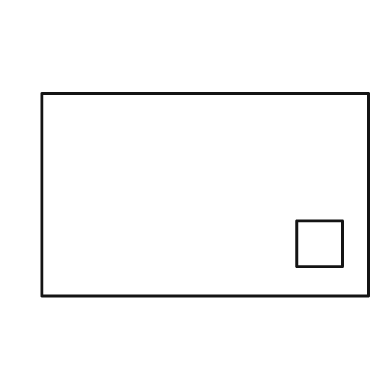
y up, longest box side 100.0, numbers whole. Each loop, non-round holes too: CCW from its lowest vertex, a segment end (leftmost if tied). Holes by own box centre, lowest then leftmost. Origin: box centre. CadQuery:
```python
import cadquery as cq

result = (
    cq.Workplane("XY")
    .moveTo(-50.0, -31.0)
    .lineTo(50.0, -31.0)
    .lineTo(50.0, 31.0)
    .lineTo(-50.0, 31.0)
    .close()
    .moveTo(28.0, -22.0)
    .lineTo(42.0, -22.0)
    .lineTo(42.0, -8.0)
    .lineTo(28.0, -8.0)
    .close()
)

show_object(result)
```